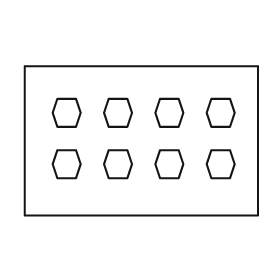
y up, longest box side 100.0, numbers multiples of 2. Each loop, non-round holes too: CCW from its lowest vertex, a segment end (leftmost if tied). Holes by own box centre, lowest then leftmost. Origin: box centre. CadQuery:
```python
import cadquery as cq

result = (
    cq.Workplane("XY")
    .moveTo(-50.0, -32.0)
    .lineTo(50.0, -32.0)
    .lineTo(50.0, 32.0)
    .lineTo(-50.0, 32.0)
    .close()
    .moveTo(-36.0, -16.0)
    .lineTo(-28.0, -16.0)
    .lineTo(-26.0, -10.0)
    .lineTo(-28.0, -4.0)
    .lineTo(-36.0, -4.0)
    .lineTo(-38.0, -10.0)
    .close()
    .moveTo(-14.0, -16.0)
    .lineTo(-6.0, -16.0)
    .lineTo(-4.0, -10.0)
    .lineTo(-6.0, -4.0)
    .lineTo(-14.0, -4.0)
    .lineTo(-16.0, -10.0)
    .close()
    .moveTo(8.0, -16.0)
    .lineTo(16.0, -16.0)
    .lineTo(18.0, -10.0)
    .lineTo(16.0, -4.0)
    .lineTo(8.0, -4.0)
    .lineTo(6.0, -10.0)
    .close()
    .moveTo(30.0, -16.0)
    .lineTo(38.0, -16.0)
    .lineTo(40.0, -10.0)
    .lineTo(38.0, -4.0)
    .lineTo(30.0, -4.0)
    .lineTo(28.0, -10.0)
    .close()
    .moveTo(-36.0, 6.0)
    .lineTo(-28.0, 6.0)
    .lineTo(-26.0, 12.0)
    .lineTo(-28.0, 18.0)
    .lineTo(-36.0, 18.0)
    .lineTo(-38.0, 12.0)
    .close()
    .moveTo(-14.0, 6.0)
    .lineTo(-6.0, 6.0)
    .lineTo(-4.0, 12.0)
    .lineTo(-6.0, 18.0)
    .lineTo(-14.0, 18.0)
    .lineTo(-16.0, 12.0)
    .close()
    .moveTo(8.0, 6.0)
    .lineTo(16.0, 6.0)
    .lineTo(18.0, 12.0)
    .lineTo(16.0, 18.0)
    .lineTo(8.0, 18.0)
    .lineTo(6.0, 12.0)
    .close()
    .moveTo(30.0, 6.0)
    .lineTo(38.0, 6.0)
    .lineTo(40.0, 12.0)
    .lineTo(38.0, 18.0)
    .lineTo(30.0, 18.0)
    .lineTo(28.0, 12.0)
    .close()
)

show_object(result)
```